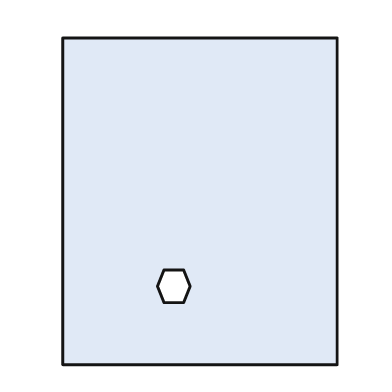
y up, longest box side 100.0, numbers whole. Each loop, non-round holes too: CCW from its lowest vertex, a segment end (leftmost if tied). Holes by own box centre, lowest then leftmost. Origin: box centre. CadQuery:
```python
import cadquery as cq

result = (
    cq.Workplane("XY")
    .moveTo(-42.0, -50.0)
    .lineTo(42.0, -50.0)
    .lineTo(42.0, 50.0)
    .lineTo(-42.0, 50.0)
    .close()
    .moveTo(-11.0, -31.0)
    .lineTo(-5.0, -31.0)
    .lineTo(-3.0, -26.0)
    .lineTo(-5.0, -21.0)
    .lineTo(-11.0, -21.0)
    .lineTo(-13.0, -26.0)
    .close()
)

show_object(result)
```